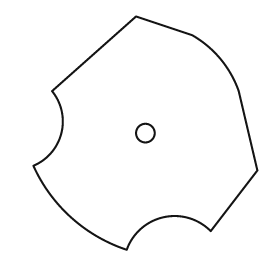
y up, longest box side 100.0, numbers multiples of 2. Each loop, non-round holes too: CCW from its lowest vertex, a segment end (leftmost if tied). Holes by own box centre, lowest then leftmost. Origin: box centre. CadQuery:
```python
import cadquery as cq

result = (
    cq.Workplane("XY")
    .moveTo(-8.0, -50.0)
    .threePointArc((8.0, -36.0), (28.0, -42.0))
    .lineTo(48.0, -16.0)
    .lineTo(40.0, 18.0)
    .threePointArc((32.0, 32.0), (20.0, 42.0))
    .lineTo(-4.0, 50.0)
    .lineTo(-40.0, 18.0)
    .threePointArc((-36.0, 0.0), (-48.0, -14.0))
    .threePointArc((-32.0, -36.0), (-8.0, -50.0))
    .close()
    .moveTo(0.0, 0.0)
    .circle(4.0)
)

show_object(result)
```